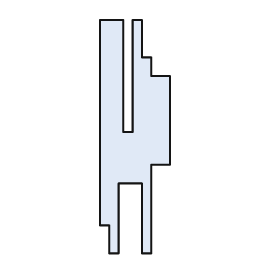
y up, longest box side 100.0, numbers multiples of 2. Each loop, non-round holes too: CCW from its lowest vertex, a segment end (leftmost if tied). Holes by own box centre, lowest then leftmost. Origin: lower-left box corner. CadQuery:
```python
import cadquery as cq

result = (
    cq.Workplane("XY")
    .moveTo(4.0, 0.0)
    .lineTo(8.0, 0.0)
    .lineTo(8.0, 30.0)
    .lineTo(18.0, 30.0)
    .lineTo(18.0, 0.0)
    .lineTo(22.0, 0.0)
    .lineTo(22.0, 38.0)
    .lineTo(30.0, 38.0)
    .lineTo(30.0, 76.0)
    .lineTo(22.0, 76.0)
    .lineTo(22.0, 84.0)
    .lineTo(18.0, 84.0)
    .lineTo(18.0, 100.0)
    .lineTo(14.0, 100.0)
    .lineTo(14.0, 52.0)
    .lineTo(10.0, 52.0)
    .lineTo(10.0, 100.0)
    .lineTo(0.0, 100.0)
    .lineTo(0.0, 12.0)
    .lineTo(4.0, 12.0)
    .close()
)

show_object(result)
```